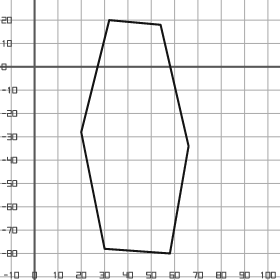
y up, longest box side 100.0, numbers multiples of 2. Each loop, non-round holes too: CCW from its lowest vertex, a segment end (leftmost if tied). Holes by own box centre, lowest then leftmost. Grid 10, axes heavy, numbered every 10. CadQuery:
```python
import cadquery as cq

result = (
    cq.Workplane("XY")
    .moveTo(58.0, -80.0)
    .lineTo(66.0, -34.0)
    .lineTo(54.0, 18.0)
    .lineTo(32.0, 20.0)
    .lineTo(20.0, -28.0)
    .lineTo(30.0, -78.0)
    .close()
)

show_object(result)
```